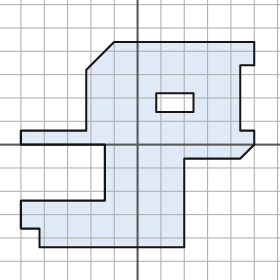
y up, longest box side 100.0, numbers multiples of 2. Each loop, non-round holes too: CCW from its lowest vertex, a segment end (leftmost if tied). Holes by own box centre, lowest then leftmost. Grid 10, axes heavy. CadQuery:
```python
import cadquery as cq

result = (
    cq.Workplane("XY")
    .moveTo(-42.0, -44.0)
    .lineTo(20.0, -44.0)
    .lineTo(20.0, -6.0)
    .lineTo(44.0, -6.0)
    .lineTo(50.0, 0.0)
    .lineTo(50.0, 6.0)
    .lineTo(44.0, 6.0)
    .lineTo(44.0, 34.0)
    .lineTo(50.0, 34.0)
    .lineTo(50.0, 44.0)
    .lineTo(-10.0, 44.0)
    .lineTo(-22.0, 32.0)
    .lineTo(-22.0, 6.0)
    .lineTo(-50.0, 6.0)
    .lineTo(-50.0, 0.0)
    .lineTo(-14.0, 0.0)
    .lineTo(-14.0, -24.0)
    .lineTo(-50.0, -24.0)
    .lineTo(-50.0, -36.0)
    .lineTo(-42.0, -36.0)
    .close()
    .moveTo(8.0, 14.0)
    .lineTo(24.0, 14.0)
    .lineTo(24.0, 22.0)
    .lineTo(8.0, 22.0)
    .close()
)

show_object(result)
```